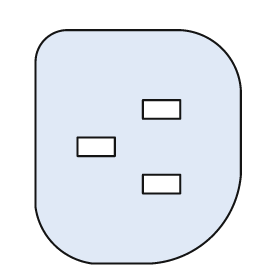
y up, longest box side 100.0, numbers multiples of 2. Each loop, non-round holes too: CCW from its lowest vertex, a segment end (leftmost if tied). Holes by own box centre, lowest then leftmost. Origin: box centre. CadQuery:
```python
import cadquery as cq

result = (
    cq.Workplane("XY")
    .moveTo(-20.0, -50.0)
    .lineTo(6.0, -50.0)
    .threePointArc((32.0, -38.0), (44.0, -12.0))
    .lineTo(44.0, 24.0)
    .threePointArc((36.0, 42.0), (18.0, 50.0))
    .lineTo(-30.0, 50.0)
    .threePointArc((-40.0, 46.0), (-44.0, 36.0))
    .lineTo(-44.0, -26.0)
    .threePointArc((-36.0, -42.0), (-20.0, -50.0))
    .close()
    .moveTo(2.0, -20.0)
    .lineTo(18.0, -20.0)
    .lineTo(18.0, -12.0)
    .lineTo(2.0, -12.0)
    .close()
    .moveTo(-26.0, -4.0)
    .lineTo(-10.0, -4.0)
    .lineTo(-10.0, 4.0)
    .lineTo(-26.0, 4.0)
    .close()
    .moveTo(2.0, 12.0)
    .lineTo(18.0, 12.0)
    .lineTo(18.0, 20.0)
    .lineTo(2.0, 20.0)
    .close()
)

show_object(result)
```